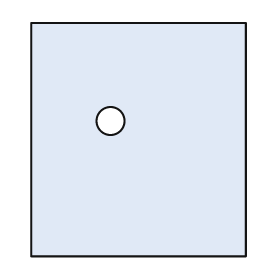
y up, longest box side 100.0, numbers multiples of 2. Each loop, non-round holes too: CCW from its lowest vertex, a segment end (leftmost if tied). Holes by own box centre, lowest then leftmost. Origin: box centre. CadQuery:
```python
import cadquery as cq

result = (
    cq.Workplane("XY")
    .moveTo(-46.0, -50.0)
    .lineTo(46.0, -50.0)
    .lineTo(46.0, 50.0)
    .lineTo(-46.0, 50.0)
    .close()
    .moveTo(-12.0, 8.0)
    .circle(6.0)
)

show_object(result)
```